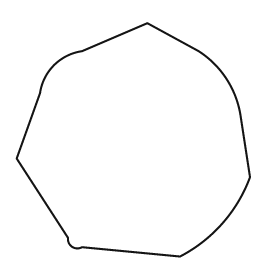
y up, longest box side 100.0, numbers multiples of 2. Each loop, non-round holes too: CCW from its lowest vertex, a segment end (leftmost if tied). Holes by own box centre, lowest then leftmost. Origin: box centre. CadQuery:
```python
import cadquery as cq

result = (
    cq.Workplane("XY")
    .moveTo(20.0, -50.0)
    .threePointArc((38.0, -36.0), (50.0, -16.0))
    .lineTo(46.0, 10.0)
    .threePointArc((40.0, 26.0), (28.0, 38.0))
    .lineTo(6.0, 50.0)
    .lineTo(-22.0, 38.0)
    .threePointArc((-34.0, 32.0), (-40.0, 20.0))
    .lineTo(-50.0, -8.0)
    .lineTo(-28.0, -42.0)
    .threePointArc((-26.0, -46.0), (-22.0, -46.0))
    .close()
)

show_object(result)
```